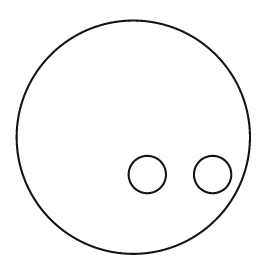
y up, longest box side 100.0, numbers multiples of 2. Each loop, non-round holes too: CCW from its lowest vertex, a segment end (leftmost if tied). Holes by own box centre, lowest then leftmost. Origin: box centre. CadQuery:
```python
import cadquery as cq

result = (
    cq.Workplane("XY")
    .moveTo(0.0, 0.0)
    .circle(50.0)
    .moveTo(6.0, -16.0)
    .circle(8.0)
    .moveTo(34.0, -16.0)
    .circle(8.0)
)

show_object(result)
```